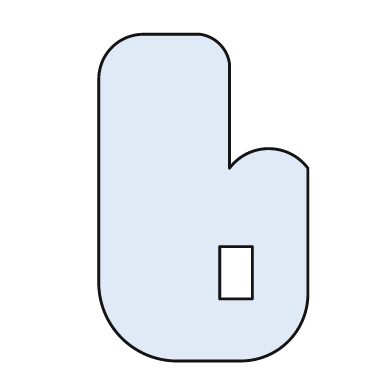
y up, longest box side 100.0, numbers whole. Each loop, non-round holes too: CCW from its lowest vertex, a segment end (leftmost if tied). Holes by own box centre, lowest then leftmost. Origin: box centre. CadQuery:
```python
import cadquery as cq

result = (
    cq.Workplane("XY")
    .moveTo(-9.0, -50.0)
    .lineTo(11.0, -50.0)
    .threePointArc((26.0, -44.0), (32.0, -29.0))
    .lineTo(32.0, 9.0)
    .threePointArc((20.0, 15.0), (8.0, 9.0))
    .lineTo(8.0, 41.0)
    .threePointArc((5.0, 47.0), (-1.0, 50.0))
    .lineTo(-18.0, 50.0)
    .threePointArc((-28.0, 46.0), (-32.0, 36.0))
    .lineTo(-32.0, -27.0)
    .threePointArc((-25.0, -43.0), (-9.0, -50.0))
    .close()
    .moveTo(5.0, -31.0)
    .lineTo(15.0, -31.0)
    .lineTo(15.0, -15.0)
    .lineTo(5.0, -15.0)
    .close()
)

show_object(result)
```